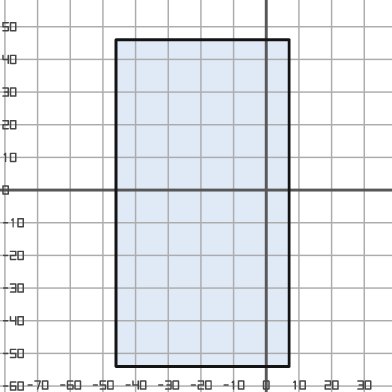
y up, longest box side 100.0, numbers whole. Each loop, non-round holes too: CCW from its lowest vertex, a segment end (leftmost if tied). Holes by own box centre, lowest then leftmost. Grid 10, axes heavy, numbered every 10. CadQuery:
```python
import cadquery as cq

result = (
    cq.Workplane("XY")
    .moveTo(-46.0, -54.0)
    .lineTo(7.0, -54.0)
    .lineTo(7.0, 46.0)
    .lineTo(-46.0, 46.0)
    .close()
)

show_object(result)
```